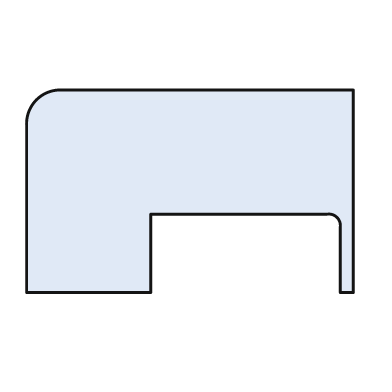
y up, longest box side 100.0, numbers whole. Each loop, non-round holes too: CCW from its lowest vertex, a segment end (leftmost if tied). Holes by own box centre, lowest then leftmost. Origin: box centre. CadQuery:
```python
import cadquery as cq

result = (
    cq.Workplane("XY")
    .moveTo(-50.0, -31.0)
    .lineTo(-12.0, -31.0)
    .lineTo(-12.0, -7.0)
    .lineTo(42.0, -7.0)
    .threePointArc((45.0, -8.0), (46.0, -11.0))
    .lineTo(46.0, -31.0)
    .lineTo(50.0, -31.0)
    .lineTo(50.0, 31.0)
    .lineTo(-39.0, 31.0)
    .threePointArc((-47.0, 28.0), (-50.0, 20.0))
    .close()
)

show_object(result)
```